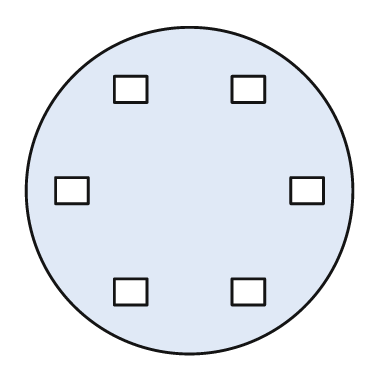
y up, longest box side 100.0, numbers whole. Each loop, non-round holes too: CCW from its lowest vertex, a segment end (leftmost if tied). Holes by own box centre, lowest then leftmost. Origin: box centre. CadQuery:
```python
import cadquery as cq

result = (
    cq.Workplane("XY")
    .moveTo(0.0, 0.0)
    .circle(50.0)
    .moveTo(-23.0, -35.0)
    .lineTo(-13.0, -35.0)
    .lineTo(-13.0, -27.0)
    .lineTo(-23.0, -27.0)
    .close()
    .moveTo(13.0, -35.0)
    .lineTo(23.0, -35.0)
    .lineTo(23.0, -27.0)
    .lineTo(13.0, -27.0)
    .close()
    .moveTo(-41.0, -4.0)
    .lineTo(-31.0, -4.0)
    .lineTo(-31.0, 4.0)
    .lineTo(-41.0, 4.0)
    .close()
    .moveTo(31.0, -4.0)
    .lineTo(41.0, -4.0)
    .lineTo(41.0, 4.0)
    .lineTo(31.0, 4.0)
    .close()
    .moveTo(-23.0, 27.0)
    .lineTo(-13.0, 27.0)
    .lineTo(-13.0, 35.0)
    .lineTo(-23.0, 35.0)
    .close()
    .moveTo(13.0, 27.0)
    .lineTo(23.0, 27.0)
    .lineTo(23.0, 35.0)
    .lineTo(13.0, 35.0)
    .close()
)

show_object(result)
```